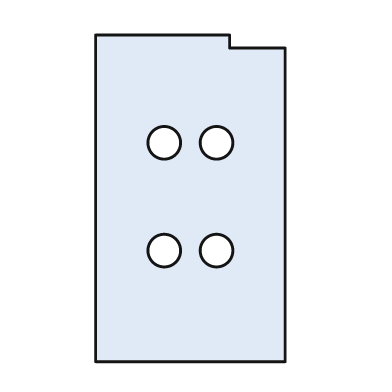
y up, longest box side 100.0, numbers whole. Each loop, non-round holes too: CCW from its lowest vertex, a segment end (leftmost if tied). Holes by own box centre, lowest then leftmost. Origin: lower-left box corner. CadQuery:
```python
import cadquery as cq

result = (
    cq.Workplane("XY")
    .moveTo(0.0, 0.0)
    .lineTo(58.0, 0.0)
    .lineTo(58.0, 96.0)
    .lineTo(41.0, 96.0)
    .lineTo(41.0, 100.0)
    .lineTo(0.0, 100.0)
    .close()
    .moveTo(21.0, 34.0)
    .circle(5.0)
    .moveTo(37.0, 34.0)
    .circle(5.0)
    .moveTo(21.0, 67.0)
    .circle(5.0)
    .moveTo(37.0, 67.0)
    .circle(5.0)
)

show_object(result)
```